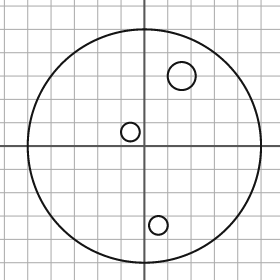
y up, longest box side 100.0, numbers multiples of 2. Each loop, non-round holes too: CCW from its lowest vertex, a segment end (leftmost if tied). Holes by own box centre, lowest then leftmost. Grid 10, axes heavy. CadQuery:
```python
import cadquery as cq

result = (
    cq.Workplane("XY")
    .moveTo(0.0, 0.0)
    .circle(50.0)
    .moveTo(6.0, -34.0)
    .circle(4.0)
    .moveTo(-6.0, 6.0)
    .circle(4.0)
    .moveTo(16.0, 30.0)
    .circle(6.0)
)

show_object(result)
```